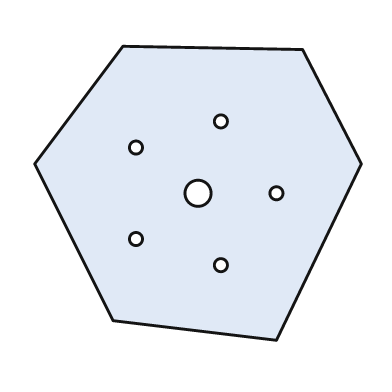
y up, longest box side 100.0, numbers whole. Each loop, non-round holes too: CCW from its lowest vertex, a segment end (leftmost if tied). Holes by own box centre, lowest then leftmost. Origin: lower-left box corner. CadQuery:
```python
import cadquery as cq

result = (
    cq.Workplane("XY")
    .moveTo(74.0, 0.0)
    .lineTo(100.0, 54.0)
    .lineTo(82.0, 89.0)
    .lineTo(27.0, 90.0)
    .lineTo(0.0, 54.0)
    .lineTo(24.0, 6.0)
    .close()
    .moveTo(57.0, 23.0)
    .circle(2.0)
    .moveTo(31.0, 31.0)
    .circle(2.0)
    .moveTo(50.0, 45.0)
    .circle(4.0)
    .moveTo(74.0, 45.0)
    .circle(2.0)
    .moveTo(31.0, 59.0)
    .circle(2.0)
    .moveTo(57.0, 67.0)
    .circle(2.0)
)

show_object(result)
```